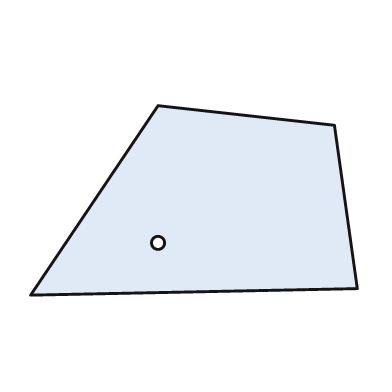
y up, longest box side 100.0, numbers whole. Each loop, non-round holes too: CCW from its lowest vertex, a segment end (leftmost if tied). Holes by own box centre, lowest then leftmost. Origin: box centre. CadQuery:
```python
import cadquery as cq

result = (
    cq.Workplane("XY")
    .moveTo(-50.0, -29.0)
    .lineTo(50.0, -27.0)
    .lineTo(43.0, 23.0)
    .lineTo(-11.0, 29.0)
    .close()
    .moveTo(-11.0, -13.0)
    .circle(2.0)
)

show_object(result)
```